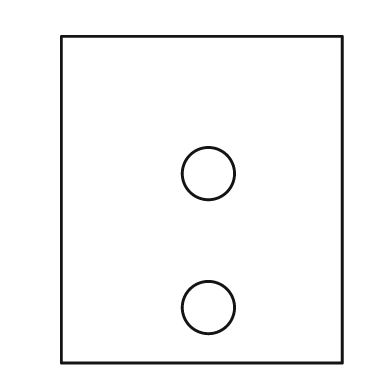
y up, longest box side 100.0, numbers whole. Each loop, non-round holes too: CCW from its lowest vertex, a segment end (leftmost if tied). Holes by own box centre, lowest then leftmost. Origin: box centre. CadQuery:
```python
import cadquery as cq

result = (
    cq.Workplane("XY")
    .moveTo(-43.0, -50.0)
    .lineTo(43.0, -50.0)
    .lineTo(43.0, 50.0)
    .lineTo(-43.0, 50.0)
    .close()
    .moveTo(2.0, -33.0)
    .circle(8.0)
    .moveTo(2.0, 8.0)
    .circle(8.0)
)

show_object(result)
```